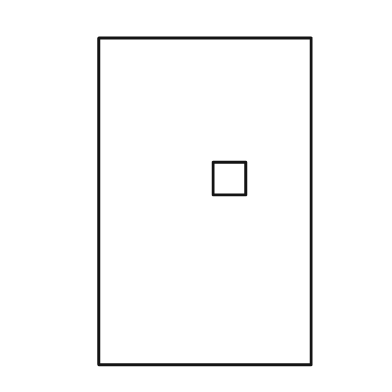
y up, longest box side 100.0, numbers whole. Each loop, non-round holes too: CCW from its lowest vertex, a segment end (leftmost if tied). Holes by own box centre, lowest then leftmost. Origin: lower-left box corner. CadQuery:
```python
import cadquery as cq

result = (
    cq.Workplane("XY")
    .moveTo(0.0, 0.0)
    .lineTo(65.0, 0.0)
    .lineTo(65.0, 100.0)
    .lineTo(0.0, 100.0)
    .close()
    .moveTo(35.0, 52.0)
    .lineTo(45.0, 52.0)
    .lineTo(45.0, 62.0)
    .lineTo(35.0, 62.0)
    .close()
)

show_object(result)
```